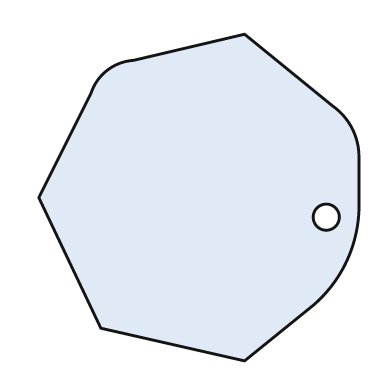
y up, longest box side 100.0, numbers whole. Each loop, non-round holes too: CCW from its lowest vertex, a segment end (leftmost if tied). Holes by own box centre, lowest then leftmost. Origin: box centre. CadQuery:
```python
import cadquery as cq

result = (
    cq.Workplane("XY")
    .moveTo(14.0, -50.0)
    .lineTo(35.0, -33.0)
    .threePointArc((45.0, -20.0), (49.0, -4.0))
    .lineTo(49.0, 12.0)
    .threePointArc((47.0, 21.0), (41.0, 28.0))
    .lineTo(14.0, 50.0)
    .lineTo(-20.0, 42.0)
    .threePointArc((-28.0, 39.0), (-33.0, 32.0))
    .lineTo(-49.0, 0.0)
    .lineTo(-30.0, -40.0)
    .close()
    .moveTo(39.0, -6.0)
    .circle(4.0)
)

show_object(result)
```